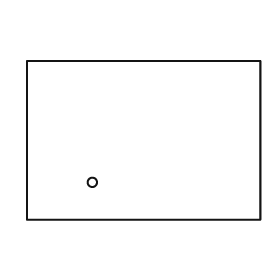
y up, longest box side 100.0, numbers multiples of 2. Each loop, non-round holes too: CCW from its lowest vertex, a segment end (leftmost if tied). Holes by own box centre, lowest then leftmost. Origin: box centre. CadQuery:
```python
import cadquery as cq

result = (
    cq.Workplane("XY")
    .moveTo(-50.0, -34.0)
    .lineTo(50.0, -34.0)
    .lineTo(50.0, 34.0)
    .lineTo(-50.0, 34.0)
    .close()
    .moveTo(-22.0, -18.0)
    .circle(2.0)
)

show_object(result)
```